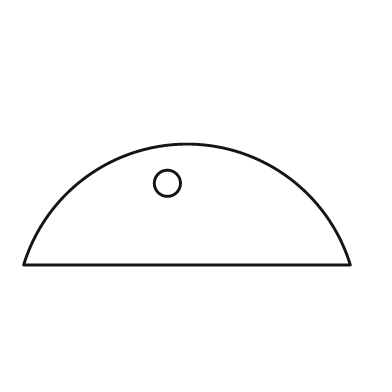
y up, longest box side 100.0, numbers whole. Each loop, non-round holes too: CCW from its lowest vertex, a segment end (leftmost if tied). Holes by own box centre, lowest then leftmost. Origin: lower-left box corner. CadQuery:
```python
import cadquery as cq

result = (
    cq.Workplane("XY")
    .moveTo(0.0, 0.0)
    .lineTo(100.0, 0.0)
    .threePointArc((50.0, 37.0), (0.0, 0.0))
    .close()
    .moveTo(44.0, 25.0)
    .circle(4.0)
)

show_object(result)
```